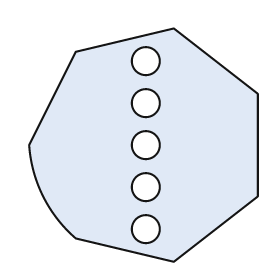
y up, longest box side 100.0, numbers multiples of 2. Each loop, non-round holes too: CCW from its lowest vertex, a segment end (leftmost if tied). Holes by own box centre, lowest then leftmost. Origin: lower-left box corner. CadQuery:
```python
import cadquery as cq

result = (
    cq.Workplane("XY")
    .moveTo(62.0, 0.0)
    .lineTo(98.0, 28.0)
    .lineTo(98.0, 72.0)
    .lineTo(62.0, 100.0)
    .lineTo(20.0, 90.0)
    .lineTo(0.0, 50.0)
    .threePointArc((6.0, 28.0), (20.0, 10.0))
    .close()
    .moveTo(50.0, 14.0)
    .circle(6.0)
    .moveTo(50.0, 32.0)
    .circle(6.0)
    .moveTo(50.0, 50.0)
    .circle(6.0)
    .moveTo(50.0, 68.0)
    .circle(6.0)
    .moveTo(50.0, 86.0)
    .circle(6.0)
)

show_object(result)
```